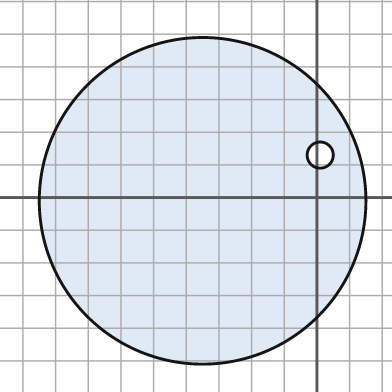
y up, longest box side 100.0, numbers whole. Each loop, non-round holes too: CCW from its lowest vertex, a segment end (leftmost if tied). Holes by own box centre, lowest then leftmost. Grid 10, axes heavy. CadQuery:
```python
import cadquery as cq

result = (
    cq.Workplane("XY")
    .moveTo(-35.0, -1.0)
    .circle(50.0)
    .moveTo(1.0, 13.0)
    .circle(4.0)
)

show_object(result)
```